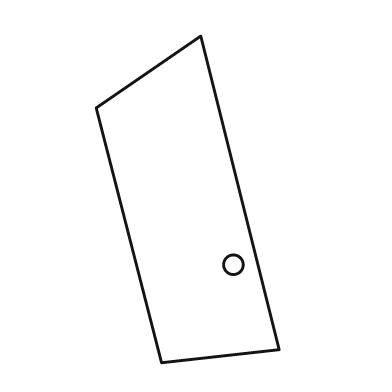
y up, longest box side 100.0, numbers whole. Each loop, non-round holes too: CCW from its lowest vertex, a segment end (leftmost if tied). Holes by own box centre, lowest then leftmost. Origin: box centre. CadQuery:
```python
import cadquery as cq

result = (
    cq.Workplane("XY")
    .moveTo(-8.0, -50.0)
    .lineTo(28.0, -46.0)
    .lineTo(4.0, 50.0)
    .lineTo(-28.0, 28.0)
    .close()
    .moveTo(14.0, -20.0)
    .circle(3.0)
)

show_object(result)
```